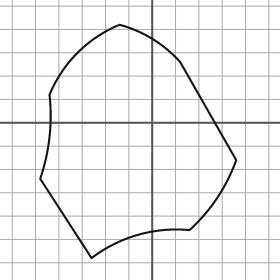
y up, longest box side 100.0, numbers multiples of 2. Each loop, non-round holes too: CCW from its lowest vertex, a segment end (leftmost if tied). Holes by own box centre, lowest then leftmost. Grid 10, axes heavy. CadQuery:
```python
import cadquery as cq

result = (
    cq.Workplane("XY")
    .moveTo(-26.0, -58.0)
    .threePointArc((-6.0, -48.0), (16.0, -46.0))
    .threePointArc((28.0, -32.0), (36.0, -16.0))
    .lineTo(12.0, 26.0)
    .threePointArc((0.0, 36.0), (-14.0, 42.0))
    .threePointArc((-32.0, 30.0), (-44.0, 12.0))
    .threePointArc((-44.0, -6.0), (-48.0, -24.0))
    .close()
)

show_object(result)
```